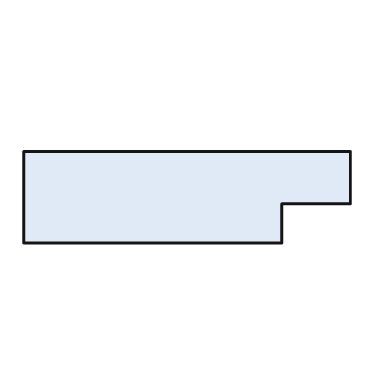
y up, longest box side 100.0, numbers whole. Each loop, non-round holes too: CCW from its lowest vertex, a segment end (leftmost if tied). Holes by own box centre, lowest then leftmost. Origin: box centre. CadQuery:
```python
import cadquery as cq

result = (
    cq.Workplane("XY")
    .moveTo(-50.0, -14.0)
    .lineTo(29.0, -14.0)
    .lineTo(29.0, -2.0)
    .lineTo(50.0, -2.0)
    .lineTo(50.0, 14.0)
    .lineTo(-50.0, 14.0)
    .close()
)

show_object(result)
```